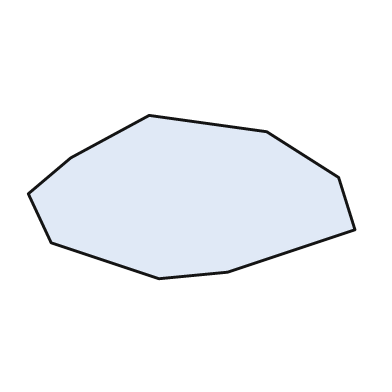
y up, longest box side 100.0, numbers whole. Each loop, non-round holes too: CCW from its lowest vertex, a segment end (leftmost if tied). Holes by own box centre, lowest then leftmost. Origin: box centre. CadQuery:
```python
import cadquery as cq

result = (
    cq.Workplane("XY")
    .moveTo(-10.0, -25.0)
    .lineTo(11.0, -23.0)
    .lineTo(50.0, -10.0)
    .lineTo(45.0, 6.0)
    .lineTo(23.0, 20.0)
    .lineTo(-13.0, 25.0)
    .lineTo(-37.0, 12.0)
    .lineTo(-50.0, 1.0)
    .lineTo(-43.0, -14.0)
    .close()
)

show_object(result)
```